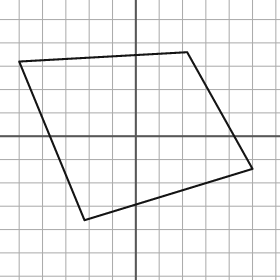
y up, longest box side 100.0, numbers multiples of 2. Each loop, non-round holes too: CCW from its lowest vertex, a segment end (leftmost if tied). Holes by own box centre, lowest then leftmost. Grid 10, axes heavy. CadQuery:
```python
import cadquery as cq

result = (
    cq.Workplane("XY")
    .moveTo(-22.0, -36.0)
    .lineTo(50.0, -14.0)
    .lineTo(22.0, 36.0)
    .lineTo(-50.0, 32.0)
    .close()
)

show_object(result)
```